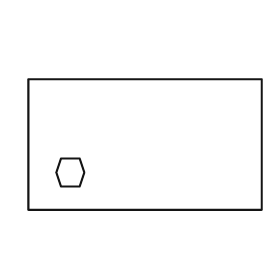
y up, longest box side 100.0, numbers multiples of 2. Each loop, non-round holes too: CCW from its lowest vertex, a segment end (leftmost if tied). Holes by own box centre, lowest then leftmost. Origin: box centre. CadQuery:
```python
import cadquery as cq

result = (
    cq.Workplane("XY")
    .moveTo(-50.0, -28.0)
    .lineTo(50.0, -28.0)
    .lineTo(50.0, 28.0)
    .lineTo(-50.0, 28.0)
    .close()
    .moveTo(-36.0, -18.0)
    .lineTo(-28.0, -18.0)
    .lineTo(-26.0, -12.0)
    .lineTo(-28.0, -6.0)
    .lineTo(-36.0, -6.0)
    .lineTo(-38.0, -12.0)
    .close()
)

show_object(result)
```